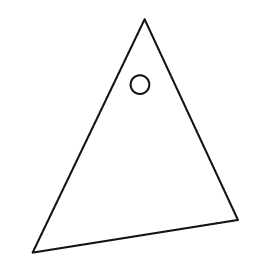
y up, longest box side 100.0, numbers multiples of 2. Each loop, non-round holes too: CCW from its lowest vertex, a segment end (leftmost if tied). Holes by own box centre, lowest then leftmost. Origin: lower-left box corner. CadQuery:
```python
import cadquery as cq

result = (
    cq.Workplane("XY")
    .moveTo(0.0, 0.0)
    .lineTo(88.0, 14.0)
    .lineTo(48.0, 100.0)
    .close()
    .moveTo(46.0, 72.0)
    .circle(4.0)
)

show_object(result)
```